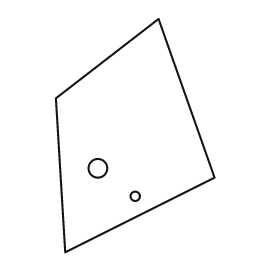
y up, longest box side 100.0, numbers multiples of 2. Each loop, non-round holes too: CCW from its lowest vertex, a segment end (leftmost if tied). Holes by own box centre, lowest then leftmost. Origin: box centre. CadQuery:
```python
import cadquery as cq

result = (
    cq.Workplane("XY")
    .moveTo(-30.0, -50.0)
    .lineTo(34.0, -18.0)
    .lineTo(10.0, 50.0)
    .lineTo(-34.0, 16.0)
    .close()
    .moveTo(0.0, -26.0)
    .circle(2.0)
    .moveTo(-16.0, -14.0)
    .circle(4.0)
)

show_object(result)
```